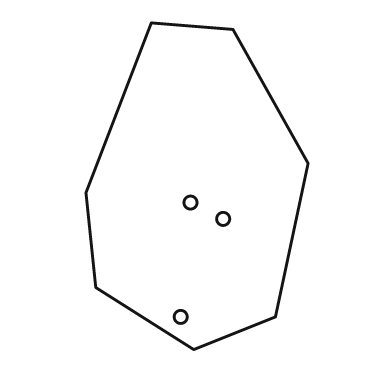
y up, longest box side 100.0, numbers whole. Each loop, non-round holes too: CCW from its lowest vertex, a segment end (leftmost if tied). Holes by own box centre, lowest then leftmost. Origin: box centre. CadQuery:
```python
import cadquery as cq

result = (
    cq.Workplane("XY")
    .moveTo(-1.0, -50.0)
    .lineTo(24.0, -40.0)
    .lineTo(34.0, 7.0)
    .lineTo(11.0, 48.0)
    .lineTo(-14.0, 50.0)
    .lineTo(-34.0, -2.0)
    .lineTo(-31.0, -31.0)
    .close()
    .moveTo(-5.0, -40.0)
    .circle(2.0)
    .moveTo(8.0, -10.0)
    .circle(2.0)
    .moveTo(-2.0, -5.0)
    .circle(2.0)
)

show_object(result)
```